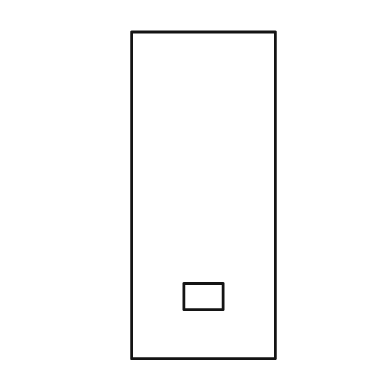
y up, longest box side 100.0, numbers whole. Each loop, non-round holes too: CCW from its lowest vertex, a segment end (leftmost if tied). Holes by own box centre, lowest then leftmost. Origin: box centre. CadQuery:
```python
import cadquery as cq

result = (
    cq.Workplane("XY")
    .moveTo(-22.0, -50.0)
    .lineTo(22.0, -50.0)
    .lineTo(22.0, 50.0)
    .lineTo(-22.0, 50.0)
    .close()
    .moveTo(-6.0, -35.0)
    .lineTo(6.0, -35.0)
    .lineTo(6.0, -27.0)
    .lineTo(-6.0, -27.0)
    .close()
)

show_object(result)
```